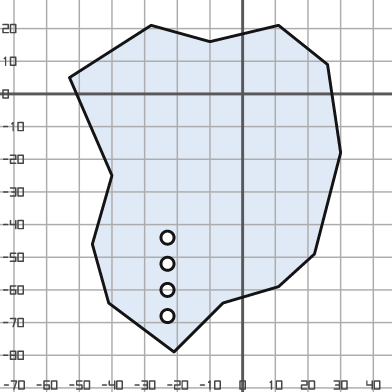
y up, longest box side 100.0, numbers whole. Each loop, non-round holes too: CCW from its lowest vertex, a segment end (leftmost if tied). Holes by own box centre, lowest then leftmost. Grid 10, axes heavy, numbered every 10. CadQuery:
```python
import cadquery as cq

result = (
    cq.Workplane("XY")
    .moveTo(-21.0, -79.0)
    .lineTo(-6.0, -64.0)
    .lineTo(11.0, -59.0)
    .lineTo(22.0, -49.0)
    .lineTo(30.0, -18.0)
    .lineTo(26.0, 9.0)
    .lineTo(11.0, 21.0)
    .lineTo(-10.0, 16.0)
    .lineTo(-28.0, 21.0)
    .lineTo(-53.0, 5.0)
    .lineTo(-40.0, -25.0)
    .lineTo(-46.0, -46.0)
    .lineTo(-41.0, -64.0)
    .close()
    .moveTo(-23.0, -68.0)
    .circle(2.0)
    .moveTo(-23.0, -60.0)
    .circle(2.0)
    .moveTo(-23.0, -52.0)
    .circle(2.0)
    .moveTo(-23.0, -44.0)
    .circle(2.0)
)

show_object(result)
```